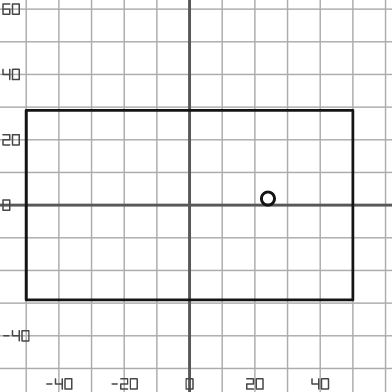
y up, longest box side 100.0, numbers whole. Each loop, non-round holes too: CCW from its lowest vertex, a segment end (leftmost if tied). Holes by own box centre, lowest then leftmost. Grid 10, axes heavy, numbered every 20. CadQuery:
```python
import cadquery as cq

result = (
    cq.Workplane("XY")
    .moveTo(-50.0, -29.0)
    .lineTo(50.0, -29.0)
    .lineTo(50.0, 29.0)
    .lineTo(-50.0, 29.0)
    .close()
    .moveTo(24.0, 2.0)
    .circle(2.0)
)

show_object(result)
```